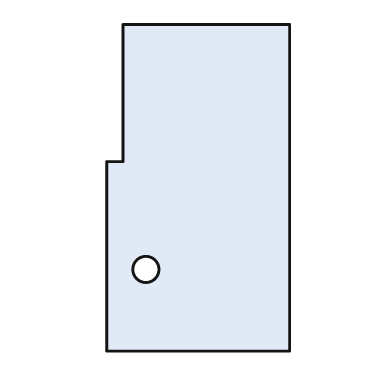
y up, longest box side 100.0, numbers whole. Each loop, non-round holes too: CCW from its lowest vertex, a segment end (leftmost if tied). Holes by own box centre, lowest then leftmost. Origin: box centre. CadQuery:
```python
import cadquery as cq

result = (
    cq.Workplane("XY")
    .moveTo(-28.0, -50.0)
    .lineTo(28.0, -50.0)
    .lineTo(28.0, 50.0)
    .lineTo(-23.0, 50.0)
    .lineTo(-23.0, 8.0)
    .lineTo(-28.0, 8.0)
    .close()
    .moveTo(-16.0, -25.0)
    .circle(4.0)
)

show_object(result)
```